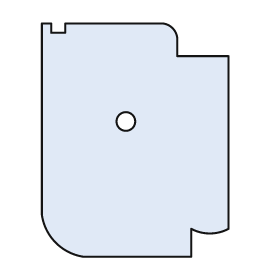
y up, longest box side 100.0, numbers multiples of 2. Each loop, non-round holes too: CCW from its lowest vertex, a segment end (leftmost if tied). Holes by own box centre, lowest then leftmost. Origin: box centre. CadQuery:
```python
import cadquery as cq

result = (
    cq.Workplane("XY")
    .moveTo(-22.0, -50.0)
    .lineTo(24.0, -50.0)
    .lineTo(24.0, -38.0)
    .threePointArc((32.0, -40.0), (40.0, -38.0))
    .lineTo(40.0, 36.0)
    .lineTo(18.0, 36.0)
    .lineTo(18.0, 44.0)
    .threePointArc((16.0, 48.0), (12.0, 50.0))
    .lineTo(-30.0, 50.0)
    .lineTo(-30.0, 46.0)
    .lineTo(-36.0, 46.0)
    .lineTo(-36.0, 50.0)
    .lineTo(-40.0, 50.0)
    .lineTo(-40.0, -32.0)
    .threePointArc((-34.0, -44.0), (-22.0, -50.0))
    .close()
    .moveTo(-4.0, 8.0)
    .circle(4.0)
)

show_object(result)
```